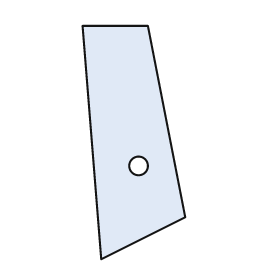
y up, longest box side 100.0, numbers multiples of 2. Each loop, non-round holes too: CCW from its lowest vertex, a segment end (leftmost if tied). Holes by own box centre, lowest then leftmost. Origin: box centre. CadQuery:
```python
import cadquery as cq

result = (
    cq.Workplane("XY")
    .moveTo(-14.0, -50.0)
    .lineTo(22.0, -32.0)
    .lineTo(6.0, 50.0)
    .lineTo(-22.0, 50.0)
    .close()
    .moveTo(2.0, -10.0)
    .circle(4.0)
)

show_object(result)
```